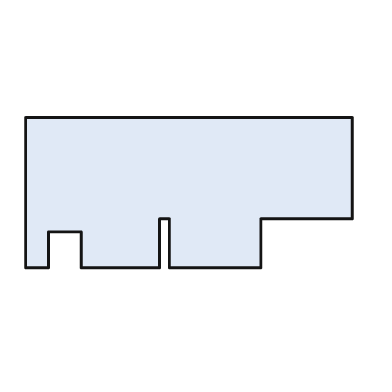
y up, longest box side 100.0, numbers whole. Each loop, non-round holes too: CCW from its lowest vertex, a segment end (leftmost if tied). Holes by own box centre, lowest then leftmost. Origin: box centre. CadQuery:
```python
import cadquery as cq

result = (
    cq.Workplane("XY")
    .moveTo(-50.0, -23.0)
    .lineTo(-43.0, -23.0)
    .lineTo(-43.0, -12.0)
    .lineTo(-33.0, -12.0)
    .lineTo(-33.0, -23.0)
    .lineTo(-9.0, -23.0)
    .lineTo(-9.0, -8.0)
    .lineTo(-6.0, -8.0)
    .lineTo(-6.0, -23.0)
    .lineTo(22.0, -23.0)
    .lineTo(22.0, -8.0)
    .lineTo(50.0, -8.0)
    .lineTo(50.0, 23.0)
    .lineTo(-50.0, 23.0)
    .close()
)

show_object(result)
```